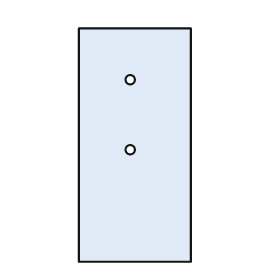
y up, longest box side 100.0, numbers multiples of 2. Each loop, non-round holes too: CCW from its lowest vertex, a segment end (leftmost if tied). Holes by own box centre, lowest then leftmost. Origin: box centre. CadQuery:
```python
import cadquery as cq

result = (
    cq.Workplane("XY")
    .moveTo(-24.0, -50.0)
    .lineTo(24.0, -50.0)
    .lineTo(24.0, 50.0)
    .lineTo(-24.0, 50.0)
    .close()
    .moveTo(-2.0, -2.0)
    .circle(2.0)
    .moveTo(-2.0, 28.0)
    .circle(2.0)
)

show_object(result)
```